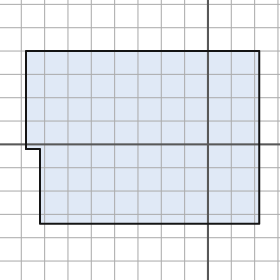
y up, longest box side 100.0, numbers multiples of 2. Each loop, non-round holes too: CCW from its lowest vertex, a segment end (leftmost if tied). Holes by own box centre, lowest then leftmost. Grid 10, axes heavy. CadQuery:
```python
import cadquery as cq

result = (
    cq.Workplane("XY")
    .moveTo(-72.0, -34.0)
    .lineTo(22.0, -34.0)
    .lineTo(22.0, 40.0)
    .lineTo(-78.0, 40.0)
    .lineTo(-78.0, -2.0)
    .lineTo(-72.0, -2.0)
    .close()
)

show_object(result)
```